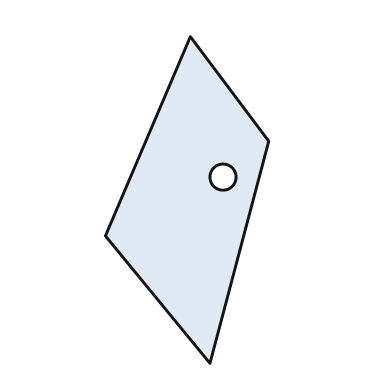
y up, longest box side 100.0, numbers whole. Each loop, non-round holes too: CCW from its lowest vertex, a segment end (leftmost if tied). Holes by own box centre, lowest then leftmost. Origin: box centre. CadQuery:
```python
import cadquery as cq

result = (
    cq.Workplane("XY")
    .moveTo(7.0, -50.0)
    .lineTo(25.0, 18.0)
    .lineTo(1.0, 50.0)
    .lineTo(-25.0, -11.0)
    .close()
    .moveTo(11.0, 7.0)
    .circle(4.0)
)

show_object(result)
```